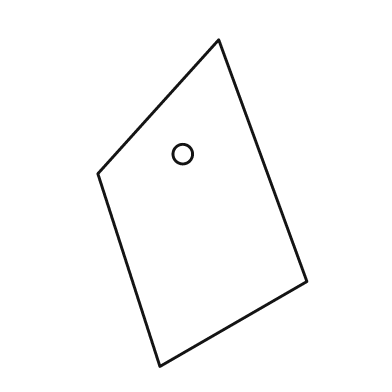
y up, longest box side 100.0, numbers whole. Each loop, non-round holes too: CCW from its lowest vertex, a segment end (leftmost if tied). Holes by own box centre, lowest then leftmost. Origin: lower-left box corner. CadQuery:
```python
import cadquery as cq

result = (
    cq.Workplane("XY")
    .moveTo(19.0, 0.0)
    .lineTo(64.0, 26.0)
    .lineTo(37.0, 100.0)
    .lineTo(0.0, 59.0)
    .close()
    .moveTo(26.0, 65.0)
    .circle(3.0)
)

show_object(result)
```